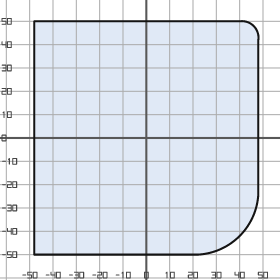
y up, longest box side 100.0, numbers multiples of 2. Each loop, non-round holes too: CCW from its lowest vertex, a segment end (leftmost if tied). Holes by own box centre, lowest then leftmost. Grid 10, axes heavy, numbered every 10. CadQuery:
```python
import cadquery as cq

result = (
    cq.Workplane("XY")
    .moveTo(-48.0, -50.0)
    .lineTo(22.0, -50.0)
    .threePointArc((40.0, -42.0), (48.0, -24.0))
    .lineTo(48.0, 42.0)
    .threePointArc((46.0, 48.0), (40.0, 50.0))
    .lineTo(-48.0, 50.0)
    .close()
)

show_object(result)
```